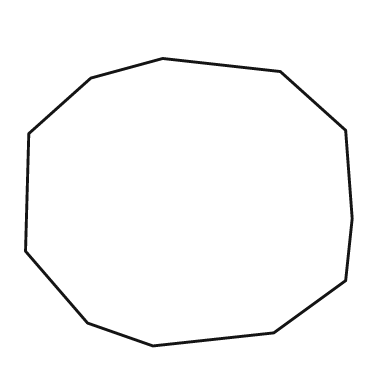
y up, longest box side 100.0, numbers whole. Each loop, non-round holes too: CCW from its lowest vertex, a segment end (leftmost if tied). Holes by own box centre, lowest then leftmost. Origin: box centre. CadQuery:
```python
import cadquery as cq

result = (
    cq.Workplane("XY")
    .moveTo(-11.0, -44.0)
    .lineTo(26.0, -40.0)
    .lineTo(48.0, -24.0)
    .lineTo(50.0, -5.0)
    .lineTo(48.0, 22.0)
    .lineTo(28.0, 40.0)
    .lineTo(-8.0, 44.0)
    .lineTo(-30.0, 38.0)
    .lineTo(-49.0, 21.0)
    .lineTo(-50.0, -15.0)
    .lineTo(-31.0, -37.0)
    .close()
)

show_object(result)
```